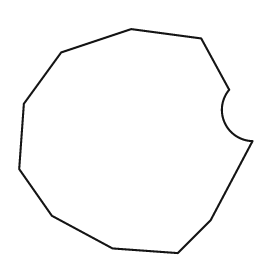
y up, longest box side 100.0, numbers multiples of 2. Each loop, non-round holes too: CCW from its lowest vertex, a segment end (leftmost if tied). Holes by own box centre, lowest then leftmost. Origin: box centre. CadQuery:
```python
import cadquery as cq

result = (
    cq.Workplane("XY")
    .moveTo(18.0, -48.0)
    .lineTo(32.0, -34.0)
    .lineTo(50.0, 0.0)
    .threePointArc((38.0, 8.0), (40.0, 22.0))
    .lineTo(28.0, 44.0)
    .lineTo(-2.0, 48.0)
    .lineTo(-32.0, 38.0)
    .lineTo(-48.0, 16.0)
    .lineTo(-50.0, -12.0)
    .lineTo(-36.0, -32.0)
    .lineTo(-10.0, -46.0)
    .close()
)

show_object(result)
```